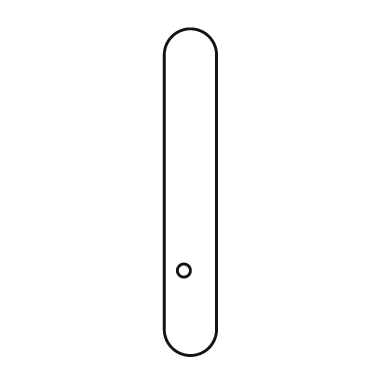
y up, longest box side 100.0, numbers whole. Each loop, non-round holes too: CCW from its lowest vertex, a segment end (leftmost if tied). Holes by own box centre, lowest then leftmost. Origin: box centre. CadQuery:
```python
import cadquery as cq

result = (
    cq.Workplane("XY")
    .moveTo(-8.0, -42.0)
    .threePointArc((0.0, -50.0), (8.0, -42.0))
    .lineTo(8.0, 42.0)
    .threePointArc((0.0, 50.0), (-8.0, 42.0))
    .close()
    .moveTo(-2.0, -24.0)
    .circle(2.0)
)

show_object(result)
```